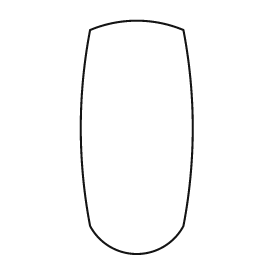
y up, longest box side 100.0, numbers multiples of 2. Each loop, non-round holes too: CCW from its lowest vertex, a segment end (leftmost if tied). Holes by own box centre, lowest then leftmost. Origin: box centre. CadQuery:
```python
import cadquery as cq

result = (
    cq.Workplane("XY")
    .moveTo(-20.0, -38.0)
    .threePointArc((0.0, -50.0), (20.0, -38.0))
    .threePointArc((24.0, 4.0), (20.0, 46.0))
    .threePointArc((0.0, 50.0), (-20.0, 46.0))
    .threePointArc((-24.0, 4.0), (-20.0, -38.0))
    .close()
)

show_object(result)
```